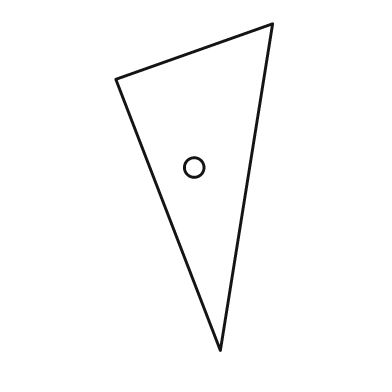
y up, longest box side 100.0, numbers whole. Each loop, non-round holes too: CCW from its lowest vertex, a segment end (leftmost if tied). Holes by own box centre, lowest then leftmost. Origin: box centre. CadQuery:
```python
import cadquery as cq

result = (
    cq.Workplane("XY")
    .moveTo(8.0, -50.0)
    .lineTo(24.0, 50.0)
    .lineTo(-24.0, 33.0)
    .close()
    .moveTo(0.0, 6.0)
    .circle(3.0)
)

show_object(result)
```